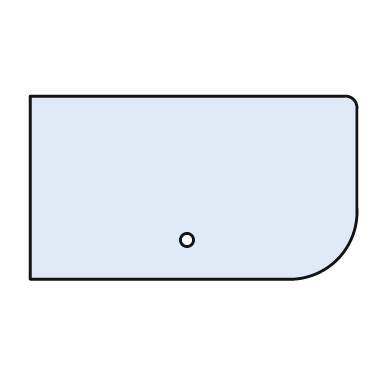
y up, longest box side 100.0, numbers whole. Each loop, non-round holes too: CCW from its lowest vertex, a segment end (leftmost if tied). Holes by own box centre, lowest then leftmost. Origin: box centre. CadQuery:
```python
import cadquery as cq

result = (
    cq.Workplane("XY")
    .moveTo(-50.0, -28.0)
    .lineTo(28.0, -28.0)
    .threePointArc((44.0, -22.0), (50.0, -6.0))
    .lineTo(50.0, 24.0)
    .threePointArc((49.0, 27.0), (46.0, 28.0))
    .lineTo(-50.0, 28.0)
    .close()
    .moveTo(-2.0, -16.0)
    .circle(2.0)
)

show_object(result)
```